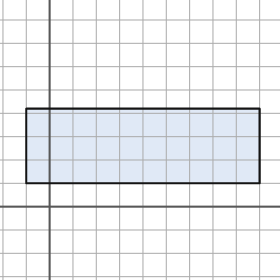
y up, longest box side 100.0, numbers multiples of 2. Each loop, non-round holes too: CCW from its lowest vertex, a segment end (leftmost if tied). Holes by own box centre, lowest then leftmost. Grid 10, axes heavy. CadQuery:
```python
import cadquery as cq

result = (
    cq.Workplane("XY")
    .moveTo(-10.0, 10.0)
    .lineTo(90.0, 10.0)
    .lineTo(90.0, 42.0)
    .lineTo(-10.0, 42.0)
    .close()
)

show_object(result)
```